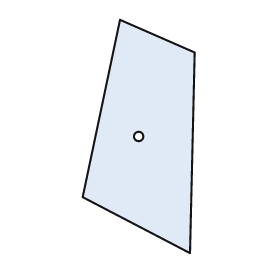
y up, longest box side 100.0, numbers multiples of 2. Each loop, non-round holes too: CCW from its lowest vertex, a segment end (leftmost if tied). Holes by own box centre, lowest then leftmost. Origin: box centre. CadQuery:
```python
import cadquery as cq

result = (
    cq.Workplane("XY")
    .moveTo(22.0, -50.0)
    .lineTo(24.0, 36.0)
    .lineTo(-8.0, 50.0)
    .lineTo(-24.0, -26.0)
    .close()
    .moveTo(0.0, 0.0)
    .circle(2.0)
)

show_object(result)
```